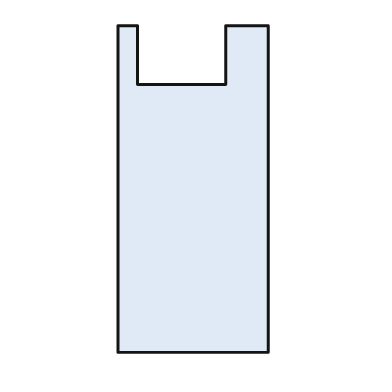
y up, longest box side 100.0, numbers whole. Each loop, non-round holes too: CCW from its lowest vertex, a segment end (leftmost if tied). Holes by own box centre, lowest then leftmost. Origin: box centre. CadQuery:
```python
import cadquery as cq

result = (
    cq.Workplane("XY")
    .moveTo(-23.0, -50.0)
    .lineTo(23.0, -50.0)
    .lineTo(23.0, 50.0)
    .lineTo(10.0, 50.0)
    .lineTo(10.0, 32.0)
    .lineTo(-17.0, 32.0)
    .lineTo(-17.0, 50.0)
    .lineTo(-23.0, 50.0)
    .close()
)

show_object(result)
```